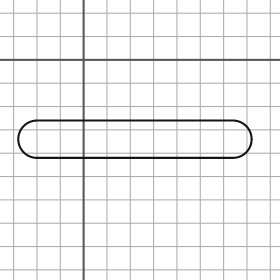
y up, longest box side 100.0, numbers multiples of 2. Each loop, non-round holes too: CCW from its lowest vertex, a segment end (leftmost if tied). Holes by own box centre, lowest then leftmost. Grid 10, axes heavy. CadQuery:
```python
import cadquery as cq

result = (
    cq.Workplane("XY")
    .moveTo(-20.0, -42.0)
    .lineTo(64.0, -42.0)
    .threePointArc((72.0, -34.0), (64.0, -26.0))
    .lineTo(-20.0, -26.0)
    .threePointArc((-28.0, -34.0), (-20.0, -42.0))
    .close()
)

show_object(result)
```